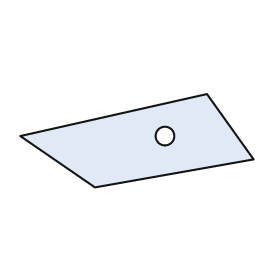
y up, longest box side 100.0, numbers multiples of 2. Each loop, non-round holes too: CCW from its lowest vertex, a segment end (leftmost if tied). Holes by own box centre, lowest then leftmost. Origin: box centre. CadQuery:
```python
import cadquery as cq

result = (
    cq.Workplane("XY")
    .moveTo(-18.0, -20.0)
    .lineTo(50.0, -8.0)
    .lineTo(30.0, 20.0)
    .lineTo(-50.0, 2.0)
    .close()
    .moveTo(12.0, 2.0)
    .circle(4.0)
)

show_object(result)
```